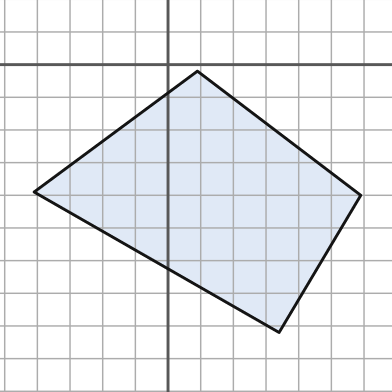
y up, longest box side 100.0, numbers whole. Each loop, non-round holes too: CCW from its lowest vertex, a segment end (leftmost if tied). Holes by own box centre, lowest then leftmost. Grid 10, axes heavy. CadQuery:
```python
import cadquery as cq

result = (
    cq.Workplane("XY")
    .moveTo(34.0, -82.0)
    .lineTo(59.0, -40.0)
    .lineTo(9.0, -2.0)
    .lineTo(-41.0, -39.0)
    .close()
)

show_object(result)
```